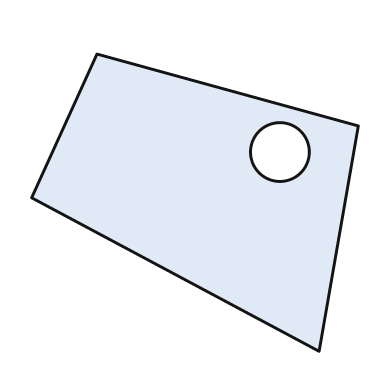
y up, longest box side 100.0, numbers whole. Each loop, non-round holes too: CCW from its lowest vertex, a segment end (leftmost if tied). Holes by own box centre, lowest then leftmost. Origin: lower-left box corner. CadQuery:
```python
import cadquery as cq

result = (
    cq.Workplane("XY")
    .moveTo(88.0, 0.0)
    .lineTo(100.0, 69.0)
    .lineTo(20.0, 91.0)
    .lineTo(0.0, 47.0)
    .close()
    .moveTo(76.0, 61.0)
    .circle(9.0)
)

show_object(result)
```